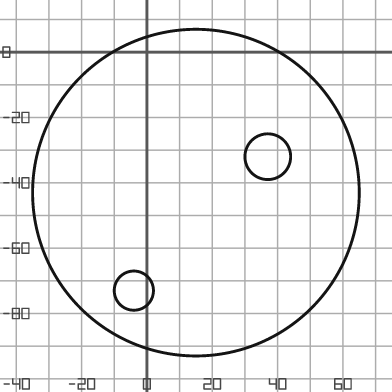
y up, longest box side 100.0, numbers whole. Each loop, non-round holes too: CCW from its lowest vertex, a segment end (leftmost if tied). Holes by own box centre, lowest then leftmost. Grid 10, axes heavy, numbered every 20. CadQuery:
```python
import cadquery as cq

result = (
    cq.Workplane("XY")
    .moveTo(15.0, -43.0)
    .circle(50.0)
    .moveTo(-4.0, -73.0)
    .circle(6.0)
    .moveTo(37.0, -32.0)
    .circle(7.0)
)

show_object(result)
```